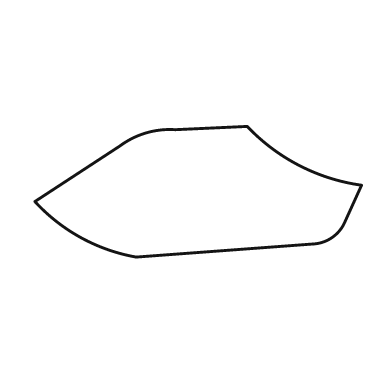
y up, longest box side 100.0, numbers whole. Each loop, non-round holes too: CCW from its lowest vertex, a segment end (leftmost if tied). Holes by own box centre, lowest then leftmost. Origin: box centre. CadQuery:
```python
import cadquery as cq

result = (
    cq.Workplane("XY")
    .moveTo(-19.0, -20.0)
    .lineTo(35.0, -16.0)
    .threePointArc((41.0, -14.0), (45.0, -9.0))
    .lineTo(50.0, 2.0)
    .threePointArc((31.0, 8.0), (15.0, 20.0))
    .lineTo(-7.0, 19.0)
    .threePointArc((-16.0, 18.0), (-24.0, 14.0))
    .lineTo(-50.0, -3.0)
    .threePointArc((-36.0, -14.0), (-19.0, -20.0))
    .close()
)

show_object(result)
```